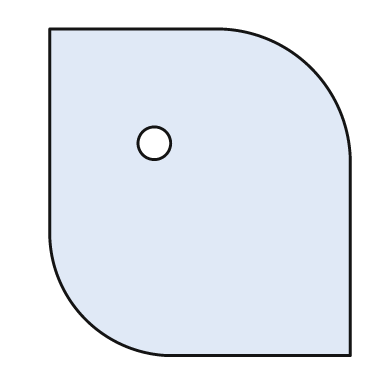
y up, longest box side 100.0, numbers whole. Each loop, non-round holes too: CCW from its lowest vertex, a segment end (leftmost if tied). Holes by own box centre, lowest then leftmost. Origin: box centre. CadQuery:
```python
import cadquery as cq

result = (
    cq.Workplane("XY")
    .moveTo(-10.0, -50.0)
    .lineTo(46.0, -50.0)
    .lineTo(46.0, 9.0)
    .threePointArc((34.0, 38.0), (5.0, 50.0))
    .lineTo(-46.0, 50.0)
    .lineTo(-46.0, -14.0)
    .threePointArc((-35.0, -39.0), (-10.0, -50.0))
    .close()
    .moveTo(-14.0, 15.0)
    .circle(5.0)
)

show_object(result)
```